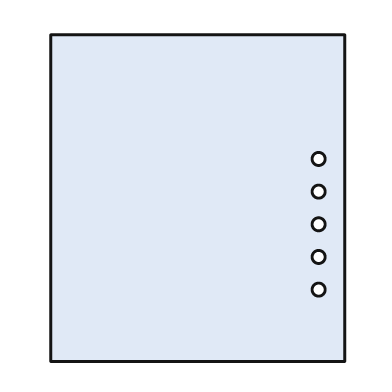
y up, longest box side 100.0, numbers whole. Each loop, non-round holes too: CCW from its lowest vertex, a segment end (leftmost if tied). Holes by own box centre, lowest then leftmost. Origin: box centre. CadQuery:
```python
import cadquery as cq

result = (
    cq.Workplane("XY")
    .moveTo(-45.0, -50.0)
    .lineTo(45.0, -50.0)
    .lineTo(45.0, 50.0)
    .lineTo(-45.0, 50.0)
    .close()
    .moveTo(37.0, -28.0)
    .circle(2.0)
    .moveTo(37.0, -18.0)
    .circle(2.0)
    .moveTo(37.0, -8.0)
    .circle(2.0)
    .moveTo(37.0, 2.0)
    .circle(2.0)
    .moveTo(37.0, 12.0)
    .circle(2.0)
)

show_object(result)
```